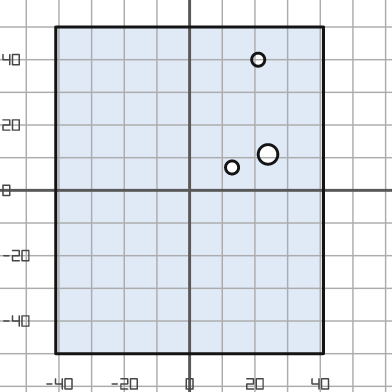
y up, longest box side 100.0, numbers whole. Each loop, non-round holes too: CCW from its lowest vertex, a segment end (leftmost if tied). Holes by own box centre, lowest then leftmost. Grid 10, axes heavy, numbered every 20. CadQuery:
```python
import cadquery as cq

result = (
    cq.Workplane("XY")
    .moveTo(-41.0, -50.0)
    .lineTo(41.0, -50.0)
    .lineTo(41.0, 50.0)
    .lineTo(-41.0, 50.0)
    .close()
    .moveTo(13.0, 7.0)
    .circle(2.0)
    .moveTo(24.0, 11.0)
    .circle(3.0)
    .moveTo(21.0, 40.0)
    .circle(2.0)
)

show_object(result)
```